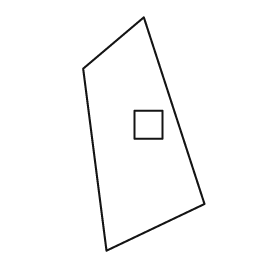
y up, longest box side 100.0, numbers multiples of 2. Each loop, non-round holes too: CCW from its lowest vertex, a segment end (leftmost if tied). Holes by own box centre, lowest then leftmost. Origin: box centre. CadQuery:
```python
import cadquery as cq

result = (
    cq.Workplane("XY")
    .moveTo(-16.0, -50.0)
    .lineTo(26.0, -30.0)
    .lineTo(0.0, 50.0)
    .lineTo(-26.0, 28.0)
    .close()
    .moveTo(-4.0, -2.0)
    .lineTo(8.0, -2.0)
    .lineTo(8.0, 10.0)
    .lineTo(-4.0, 10.0)
    .close()
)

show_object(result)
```